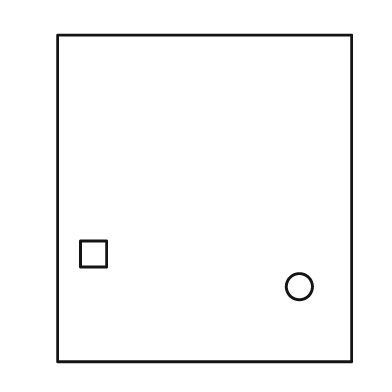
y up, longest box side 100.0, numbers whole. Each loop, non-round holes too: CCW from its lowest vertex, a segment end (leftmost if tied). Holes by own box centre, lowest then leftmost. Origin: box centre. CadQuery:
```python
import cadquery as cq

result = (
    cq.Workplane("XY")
    .moveTo(-45.0, -50.0)
    .lineTo(45.0, -50.0)
    .lineTo(45.0, 50.0)
    .lineTo(-45.0, 50.0)
    .close()
    .moveTo(29.0, -27.0)
    .circle(4.0)
    .moveTo(-38.0, -21.0)
    .lineTo(-30.0, -21.0)
    .lineTo(-30.0, -13.0)
    .lineTo(-38.0, -13.0)
    .close()
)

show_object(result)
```